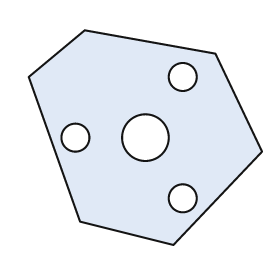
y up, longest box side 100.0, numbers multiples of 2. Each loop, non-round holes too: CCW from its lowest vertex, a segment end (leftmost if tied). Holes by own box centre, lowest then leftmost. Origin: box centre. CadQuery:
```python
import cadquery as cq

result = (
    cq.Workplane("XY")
    .moveTo(12.0, -46.0)
    .lineTo(50.0, -6.0)
    .lineTo(30.0, 36.0)
    .lineTo(-26.0, 46.0)
    .lineTo(-50.0, 26.0)
    .lineTo(-28.0, -36.0)
    .close()
    .moveTo(16.0, -26.0)
    .circle(6.0)
    .moveTo(-30.0, 0.0)
    .circle(6.0)
    .moveTo(0.0, 0.0)
    .circle(10.0)
    .moveTo(16.0, 26.0)
    .circle(6.0)
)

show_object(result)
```